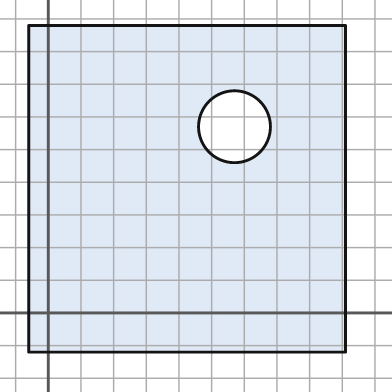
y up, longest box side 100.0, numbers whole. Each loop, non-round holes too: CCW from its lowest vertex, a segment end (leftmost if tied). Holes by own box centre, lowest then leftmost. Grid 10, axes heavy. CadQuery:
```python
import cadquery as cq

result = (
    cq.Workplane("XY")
    .moveTo(-6.0, -12.0)
    .lineTo(91.0, -12.0)
    .lineTo(91.0, 88.0)
    .lineTo(-6.0, 88.0)
    .close()
    .moveTo(57.0, 57.0)
    .circle(11.0)
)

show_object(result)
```